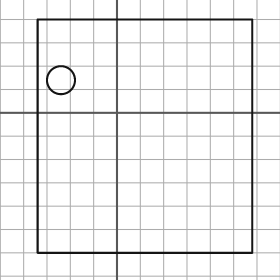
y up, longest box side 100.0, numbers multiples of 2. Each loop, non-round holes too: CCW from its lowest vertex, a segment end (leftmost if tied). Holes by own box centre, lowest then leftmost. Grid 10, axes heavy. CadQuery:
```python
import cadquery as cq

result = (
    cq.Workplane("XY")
    .moveTo(-34.0, -60.0)
    .lineTo(58.0, -60.0)
    .lineTo(58.0, 40.0)
    .lineTo(-34.0, 40.0)
    .close()
    .moveTo(-24.0, 14.0)
    .circle(6.0)
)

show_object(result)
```